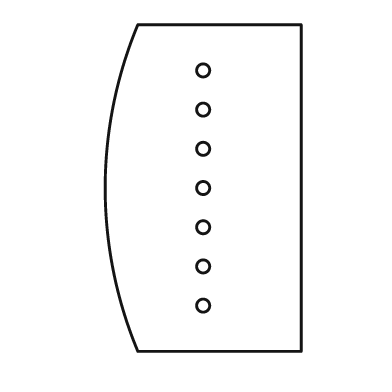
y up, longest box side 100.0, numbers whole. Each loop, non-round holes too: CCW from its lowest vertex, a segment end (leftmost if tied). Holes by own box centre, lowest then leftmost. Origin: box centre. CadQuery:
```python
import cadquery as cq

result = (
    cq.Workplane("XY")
    .moveTo(-20.0, -50.0)
    .lineTo(30.0, -50.0)
    .lineTo(30.0, 50.0)
    .lineTo(-20.0, 50.0)
    .threePointArc((-30.0, 0.0), (-20.0, -50.0))
    .close()
    .moveTo(0.0, -36.0)
    .circle(2.0)
    .moveTo(0.0, -24.0)
    .circle(2.0)
    .moveTo(0.0, -12.0)
    .circle(2.0)
    .moveTo(0.0, 0.0)
    .circle(2.0)
    .moveTo(0.0, 12.0)
    .circle(2.0)
    .moveTo(0.0, 24.0)
    .circle(2.0)
    .moveTo(0.0, 36.0)
    .circle(2.0)
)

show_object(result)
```